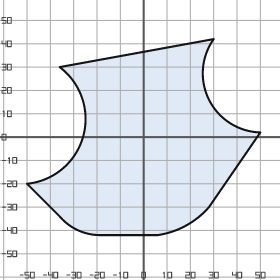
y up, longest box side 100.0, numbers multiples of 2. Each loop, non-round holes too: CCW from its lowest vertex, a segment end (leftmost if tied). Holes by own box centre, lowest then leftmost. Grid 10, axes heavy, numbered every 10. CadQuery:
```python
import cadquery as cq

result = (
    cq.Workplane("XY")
    .moveTo(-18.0, -42.0)
    .lineTo(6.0, -42.0)
    .threePointArc((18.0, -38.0), (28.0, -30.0))
    .lineTo(50.0, 2.0)
    .threePointArc((28.0, 16.0), (30.0, 42.0))
    .lineTo(-36.0, 30.0)
    .threePointArc((-26.0, 0.0), (-50.0, -20.0))
    .lineTo(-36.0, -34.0)
    .threePointArc((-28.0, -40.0), (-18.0, -42.0))
    .close()
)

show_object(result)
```